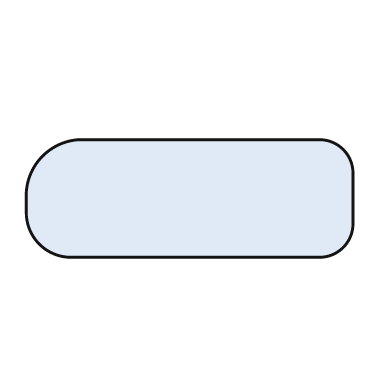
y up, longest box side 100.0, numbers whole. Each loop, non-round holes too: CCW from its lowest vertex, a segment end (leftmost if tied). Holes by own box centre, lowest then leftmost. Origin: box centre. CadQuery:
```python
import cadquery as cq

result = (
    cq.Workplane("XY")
    .moveTo(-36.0, -18.0)
    .lineTo(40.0, -18.0)
    .threePointArc((47.0, -15.0), (50.0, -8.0))
    .lineTo(50.0, 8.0)
    .threePointArc((47.0, 15.0), (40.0, 18.0))
    .lineTo(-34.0, 18.0)
    .threePointArc((-45.0, 13.0), (-50.0, 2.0))
    .lineTo(-50.0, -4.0)
    .threePointArc((-46.0, -14.0), (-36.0, -18.0))
    .close()
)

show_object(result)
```